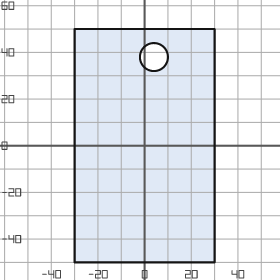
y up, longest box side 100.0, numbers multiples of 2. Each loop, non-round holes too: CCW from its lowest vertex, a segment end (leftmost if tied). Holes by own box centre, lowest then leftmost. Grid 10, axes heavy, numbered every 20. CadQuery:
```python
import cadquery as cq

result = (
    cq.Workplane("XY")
    .moveTo(-30.0, -50.0)
    .lineTo(30.0, -50.0)
    .lineTo(30.0, 50.0)
    .lineTo(-30.0, 50.0)
    .close()
    .moveTo(4.0, 38.0)
    .circle(6.0)
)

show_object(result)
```